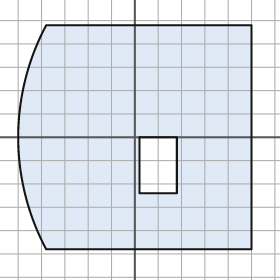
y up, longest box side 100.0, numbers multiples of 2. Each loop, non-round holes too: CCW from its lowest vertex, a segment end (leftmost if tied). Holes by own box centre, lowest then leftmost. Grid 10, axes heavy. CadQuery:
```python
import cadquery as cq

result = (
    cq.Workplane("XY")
    .moveTo(-38.0, -48.0)
    .lineTo(50.0, -48.0)
    .lineTo(50.0, 48.0)
    .lineTo(-38.0, 48.0)
    .threePointArc((-50.0, 0.0), (-38.0, -48.0))
    .close()
    .moveTo(2.0, -24.0)
    .lineTo(18.0, -24.0)
    .lineTo(18.0, 0.0)
    .lineTo(2.0, 0.0)
    .close()
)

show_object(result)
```